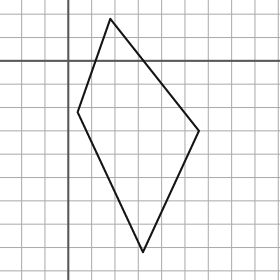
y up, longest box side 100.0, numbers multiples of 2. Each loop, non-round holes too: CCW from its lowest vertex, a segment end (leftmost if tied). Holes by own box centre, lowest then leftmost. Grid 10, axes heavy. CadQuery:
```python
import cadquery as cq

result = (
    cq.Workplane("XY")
    .moveTo(32.0, -82.0)
    .lineTo(56.0, -30.0)
    .lineTo(18.0, 18.0)
    .lineTo(4.0, -22.0)
    .close()
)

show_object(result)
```